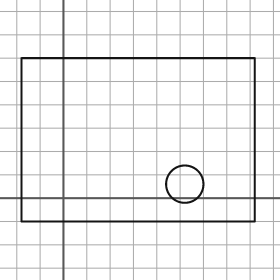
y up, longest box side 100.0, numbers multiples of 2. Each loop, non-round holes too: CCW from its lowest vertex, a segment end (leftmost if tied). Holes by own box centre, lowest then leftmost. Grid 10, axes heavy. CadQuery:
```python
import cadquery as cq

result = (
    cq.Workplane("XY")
    .moveTo(-18.0, -10.0)
    .lineTo(82.0, -10.0)
    .lineTo(82.0, 60.0)
    .lineTo(-18.0, 60.0)
    .close()
    .moveTo(52.0, 6.0)
    .circle(8.0)
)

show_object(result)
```